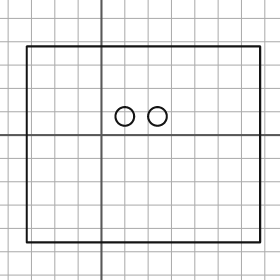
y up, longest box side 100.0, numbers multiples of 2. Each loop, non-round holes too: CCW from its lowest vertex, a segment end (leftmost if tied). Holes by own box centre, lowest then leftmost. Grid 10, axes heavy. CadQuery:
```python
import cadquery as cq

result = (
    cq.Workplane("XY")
    .moveTo(-32.0, -46.0)
    .lineTo(68.0, -46.0)
    .lineTo(68.0, 38.0)
    .lineTo(-32.0, 38.0)
    .close()
    .moveTo(10.0, 8.0)
    .circle(4.0)
    .moveTo(24.0, 8.0)
    .circle(4.0)
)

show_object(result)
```